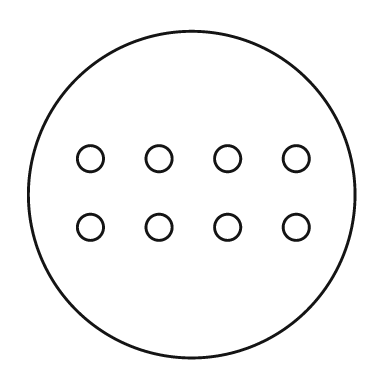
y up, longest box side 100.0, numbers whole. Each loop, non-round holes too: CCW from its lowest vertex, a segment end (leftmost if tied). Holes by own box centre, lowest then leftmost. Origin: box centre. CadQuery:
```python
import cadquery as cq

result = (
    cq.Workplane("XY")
    .moveTo(0.0, 0.0)
    .circle(50.0)
    .moveTo(-31.0, -10.0)
    .circle(4.0)
    .moveTo(-10.0, -10.0)
    .circle(4.0)
    .moveTo(11.0, -10.0)
    .circle(4.0)
    .moveTo(32.0, -10.0)
    .circle(4.0)
    .moveTo(-31.0, 11.0)
    .circle(4.0)
    .moveTo(-10.0, 11.0)
    .circle(4.0)
    .moveTo(11.0, 11.0)
    .circle(4.0)
    .moveTo(32.0, 11.0)
    .circle(4.0)
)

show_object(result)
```